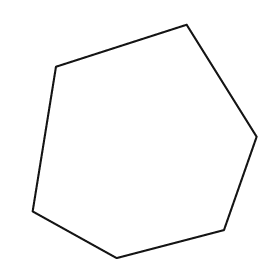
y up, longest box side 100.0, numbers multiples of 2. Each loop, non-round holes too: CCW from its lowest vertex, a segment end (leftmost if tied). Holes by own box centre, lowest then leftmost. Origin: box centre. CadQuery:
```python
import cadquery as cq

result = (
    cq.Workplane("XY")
    .moveTo(-12.0, -50.0)
    .lineTo(34.0, -38.0)
    .lineTo(48.0, 2.0)
    .lineTo(18.0, 50.0)
    .lineTo(-38.0, 32.0)
    .lineTo(-48.0, -30.0)
    .close()
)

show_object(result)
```